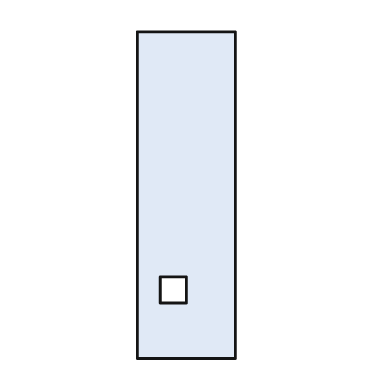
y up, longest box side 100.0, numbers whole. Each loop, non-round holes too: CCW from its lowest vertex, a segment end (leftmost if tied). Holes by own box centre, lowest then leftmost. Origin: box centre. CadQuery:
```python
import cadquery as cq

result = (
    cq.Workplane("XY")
    .moveTo(-15.0, -50.0)
    .lineTo(15.0, -50.0)
    .lineTo(15.0, 50.0)
    .lineTo(-15.0, 50.0)
    .close()
    .moveTo(-8.0, -33.0)
    .lineTo(0.0, -33.0)
    .lineTo(0.0, -25.0)
    .lineTo(-8.0, -25.0)
    .close()
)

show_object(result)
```